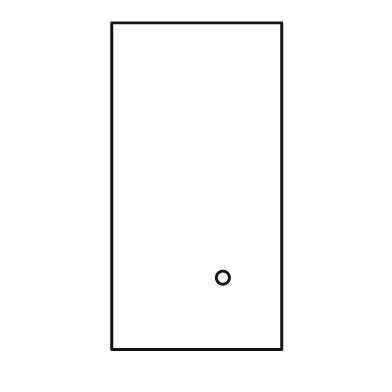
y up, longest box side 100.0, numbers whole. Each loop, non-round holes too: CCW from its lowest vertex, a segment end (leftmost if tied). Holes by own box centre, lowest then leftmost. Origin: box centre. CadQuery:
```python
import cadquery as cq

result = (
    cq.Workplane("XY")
    .moveTo(-26.0, -50.0)
    .lineTo(26.0, -50.0)
    .lineTo(26.0, 50.0)
    .lineTo(-26.0, 50.0)
    .close()
    .moveTo(8.0, -28.0)
    .circle(2.0)
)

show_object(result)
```